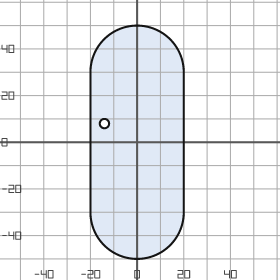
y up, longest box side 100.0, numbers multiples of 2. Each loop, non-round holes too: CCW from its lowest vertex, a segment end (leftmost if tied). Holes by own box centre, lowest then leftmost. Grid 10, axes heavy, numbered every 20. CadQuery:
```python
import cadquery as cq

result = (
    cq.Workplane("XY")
    .moveTo(-20.0, -30.0)
    .threePointArc((0.0, -50.0), (20.0, -30.0))
    .lineTo(20.0, 30.0)
    .threePointArc((0.0, 50.0), (-20.0, 30.0))
    .close()
    .moveTo(-14.0, 8.0)
    .circle(2.0)
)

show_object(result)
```